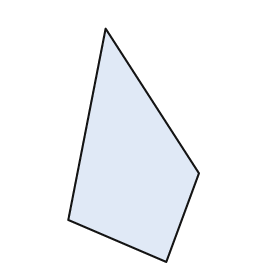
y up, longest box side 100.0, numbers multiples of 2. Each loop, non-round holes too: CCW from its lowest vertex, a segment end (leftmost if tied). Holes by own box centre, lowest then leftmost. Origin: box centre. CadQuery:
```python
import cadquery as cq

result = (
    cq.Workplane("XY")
    .moveTo(14.0, -50.0)
    .lineTo(28.0, -12.0)
    .lineTo(-12.0, 50.0)
    .lineTo(-28.0, -32.0)
    .close()
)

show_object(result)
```